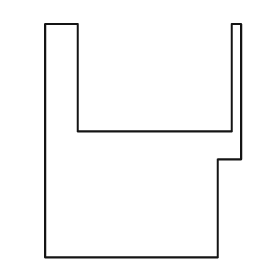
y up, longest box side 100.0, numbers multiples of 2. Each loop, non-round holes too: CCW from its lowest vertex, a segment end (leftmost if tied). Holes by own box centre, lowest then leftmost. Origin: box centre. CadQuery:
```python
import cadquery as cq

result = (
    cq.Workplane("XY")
    .moveTo(-42.0, -50.0)
    .lineTo(32.0, -50.0)
    .lineTo(32.0, -8.0)
    .lineTo(42.0, -8.0)
    .lineTo(42.0, 50.0)
    .lineTo(38.0, 50.0)
    .lineTo(38.0, 4.0)
    .lineTo(-28.0, 4.0)
    .lineTo(-28.0, 50.0)
    .lineTo(-42.0, 50.0)
    .close()
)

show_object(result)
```